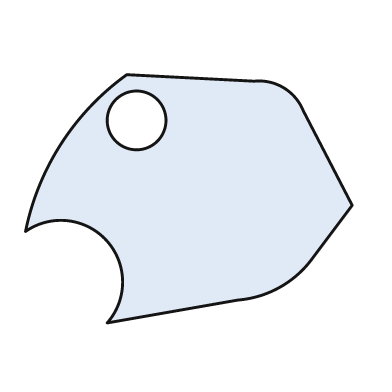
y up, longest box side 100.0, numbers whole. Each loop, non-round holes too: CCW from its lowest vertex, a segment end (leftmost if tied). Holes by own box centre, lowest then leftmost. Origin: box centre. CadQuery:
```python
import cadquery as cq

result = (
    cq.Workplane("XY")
    .moveTo(-25.0, -38.0)
    .lineTo(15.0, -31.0)
    .threePointArc((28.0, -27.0), (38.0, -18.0))
    .lineTo(50.0, -2.0)
    .lineTo(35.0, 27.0)
    .threePointArc((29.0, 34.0), (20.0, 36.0))
    .lineTo(-19.0, 38.0)
    .threePointArc((-39.0, 17.0), (-50.0, -10.0))
    .threePointArc((-25.0, -13.0), (-25.0, -38.0))
    .close()
    .moveTo(-16.0, 24.0)
    .circle(9.0)
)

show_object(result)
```